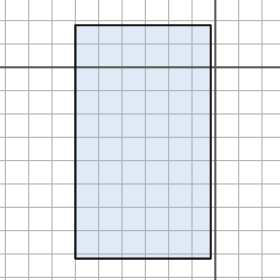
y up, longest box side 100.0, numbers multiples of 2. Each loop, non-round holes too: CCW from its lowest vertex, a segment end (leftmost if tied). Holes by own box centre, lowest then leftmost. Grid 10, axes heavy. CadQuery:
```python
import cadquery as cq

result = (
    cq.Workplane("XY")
    .moveTo(-60.0, -82.0)
    .lineTo(-2.0, -82.0)
    .lineTo(-2.0, 18.0)
    .lineTo(-60.0, 18.0)
    .close()
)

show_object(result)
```